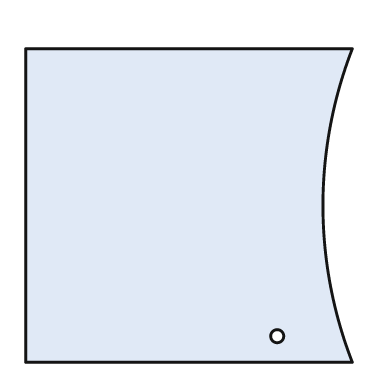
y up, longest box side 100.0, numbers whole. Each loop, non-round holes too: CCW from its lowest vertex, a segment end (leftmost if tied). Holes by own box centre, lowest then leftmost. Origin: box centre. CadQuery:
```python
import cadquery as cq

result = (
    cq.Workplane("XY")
    .moveTo(-50.0, -48.0)
    .lineTo(50.0, -48.0)
    .threePointArc((41.0, 0.0), (50.0, 48.0))
    .lineTo(-50.0, 48.0)
    .close()
    .moveTo(27.0, -40.0)
    .circle(2.0)
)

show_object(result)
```